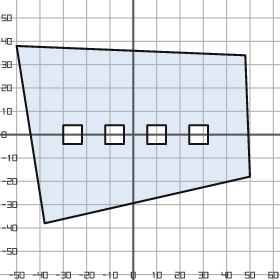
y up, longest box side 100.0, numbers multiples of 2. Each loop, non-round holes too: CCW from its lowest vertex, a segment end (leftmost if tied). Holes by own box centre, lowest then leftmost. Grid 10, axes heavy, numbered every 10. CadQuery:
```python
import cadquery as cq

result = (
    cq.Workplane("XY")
    .moveTo(-38.0, -38.0)
    .lineTo(50.0, -18.0)
    .lineTo(48.0, 34.0)
    .lineTo(-50.0, 38.0)
    .close()
    .moveTo(-30.0, -4.0)
    .lineTo(-22.0, -4.0)
    .lineTo(-22.0, 4.0)
    .lineTo(-30.0, 4.0)
    .close()
    .moveTo(-12.0, -4.0)
    .lineTo(-4.0, -4.0)
    .lineTo(-4.0, 4.0)
    .lineTo(-12.0, 4.0)
    .close()
    .moveTo(6.0, -4.0)
    .lineTo(14.0, -4.0)
    .lineTo(14.0, 4.0)
    .lineTo(6.0, 4.0)
    .close()
    .moveTo(24.0, -4.0)
    .lineTo(32.0, -4.0)
    .lineTo(32.0, 4.0)
    .lineTo(24.0, 4.0)
    .close()
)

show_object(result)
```